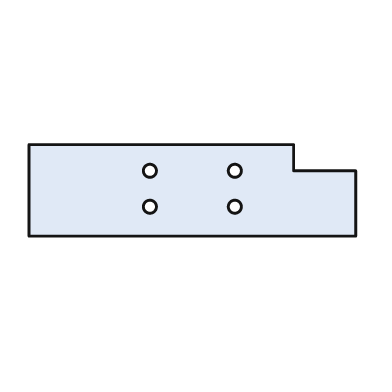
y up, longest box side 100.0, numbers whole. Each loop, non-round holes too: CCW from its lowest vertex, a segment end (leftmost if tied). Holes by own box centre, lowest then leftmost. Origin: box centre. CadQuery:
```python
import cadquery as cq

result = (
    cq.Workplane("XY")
    .moveTo(-50.0, -14.0)
    .lineTo(50.0, -14.0)
    .lineTo(50.0, 6.0)
    .lineTo(31.0, 6.0)
    .lineTo(31.0, 14.0)
    .lineTo(-50.0, 14.0)
    .close()
    .moveTo(-13.0, -5.0)
    .circle(2.0)
    .moveTo(13.0, -5.0)
    .circle(2.0)
    .moveTo(-13.0, 6.0)
    .circle(2.0)
    .moveTo(13.0, 6.0)
    .circle(2.0)
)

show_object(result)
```